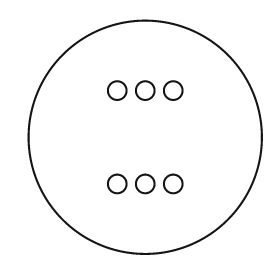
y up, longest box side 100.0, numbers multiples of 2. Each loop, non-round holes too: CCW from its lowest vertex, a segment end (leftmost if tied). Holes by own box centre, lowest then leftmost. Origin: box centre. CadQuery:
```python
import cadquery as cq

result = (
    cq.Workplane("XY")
    .moveTo(0.0, 0.0)
    .circle(50.0)
    .moveTo(-12.0, -20.0)
    .circle(4.0)
    .moveTo(0.0, -20.0)
    .circle(4.0)
    .moveTo(12.0, -20.0)
    .circle(4.0)
    .moveTo(-12.0, 20.0)
    .circle(4.0)
    .moveTo(0.0, 20.0)
    .circle(4.0)
    .moveTo(12.0, 20.0)
    .circle(4.0)
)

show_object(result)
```